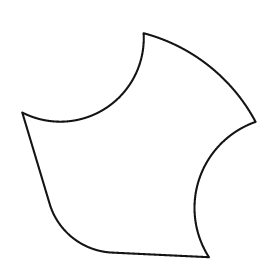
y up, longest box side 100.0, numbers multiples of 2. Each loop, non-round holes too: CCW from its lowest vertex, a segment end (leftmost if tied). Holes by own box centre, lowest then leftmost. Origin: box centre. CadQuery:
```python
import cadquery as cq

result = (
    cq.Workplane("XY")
    .moveTo(30.0, -48.0)
    .threePointArc((26.0, -14.0), (50.0, 10.0))
    .threePointArc((30.0, 34.0), (2.0, 48.0))
    .threePointArc((-14.0, 16.0), (-50.0, 14.0))
    .lineTo(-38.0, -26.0)
    .threePointArc((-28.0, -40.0), (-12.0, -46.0))
    .close()
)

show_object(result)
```